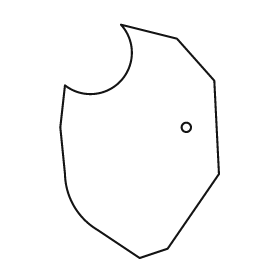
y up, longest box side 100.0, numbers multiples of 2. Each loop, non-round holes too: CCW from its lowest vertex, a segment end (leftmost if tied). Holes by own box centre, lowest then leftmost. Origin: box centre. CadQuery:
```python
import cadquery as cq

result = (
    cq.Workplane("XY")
    .moveTo(0.0, -50.0)
    .lineTo(12.0, -46.0)
    .lineTo(34.0, -14.0)
    .lineTo(32.0, 26.0)
    .lineTo(16.0, 44.0)
    .lineTo(-8.0, 50.0)
    .threePointArc((-8.0, 26.0), (-32.0, 24.0))
    .lineTo(-34.0, 6.0)
    .lineTo(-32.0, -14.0)
    .threePointArc((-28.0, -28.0), (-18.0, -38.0))
    .close()
    .moveTo(20.0, 6.0)
    .circle(2.0)
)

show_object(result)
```